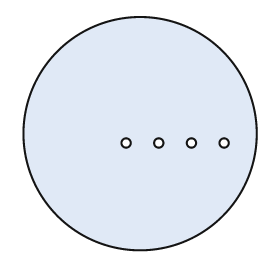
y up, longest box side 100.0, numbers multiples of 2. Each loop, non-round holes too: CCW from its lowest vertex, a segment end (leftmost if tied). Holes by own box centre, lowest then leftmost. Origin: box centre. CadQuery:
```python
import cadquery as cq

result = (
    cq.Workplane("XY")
    .moveTo(0.0, 0.0)
    .circle(50.0)
    .moveTo(-6.0, -4.0)
    .circle(2.0)
    .moveTo(8.0, -4.0)
    .circle(2.0)
    .moveTo(22.0, -4.0)
    .circle(2.0)
    .moveTo(36.0, -4.0)
    .circle(2.0)
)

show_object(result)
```